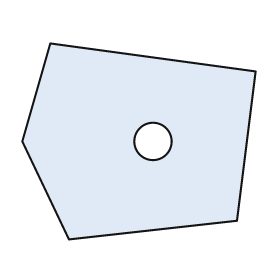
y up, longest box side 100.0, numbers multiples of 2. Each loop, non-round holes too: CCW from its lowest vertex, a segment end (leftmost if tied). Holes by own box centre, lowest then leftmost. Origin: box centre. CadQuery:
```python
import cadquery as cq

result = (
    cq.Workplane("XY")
    .moveTo(-30.0, -42.0)
    .lineTo(42.0, -34.0)
    .lineTo(50.0, 30.0)
    .lineTo(-38.0, 42.0)
    .lineTo(-50.0, 0.0)
    .close()
    .moveTo(6.0, 0.0)
    .circle(8.0)
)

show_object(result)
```